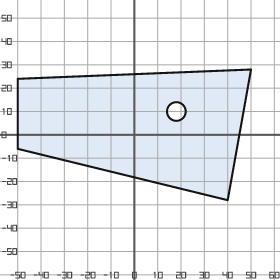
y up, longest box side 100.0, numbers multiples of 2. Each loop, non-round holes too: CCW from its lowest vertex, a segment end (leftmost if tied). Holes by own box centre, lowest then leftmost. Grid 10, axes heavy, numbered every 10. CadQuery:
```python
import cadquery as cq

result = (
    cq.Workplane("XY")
    .moveTo(40.0, -28.0)
    .lineTo(50.0, 28.0)
    .lineTo(-50.0, 24.0)
    .lineTo(-50.0, -6.0)
    .close()
    .moveTo(18.0, 10.0)
    .circle(4.0)
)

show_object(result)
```